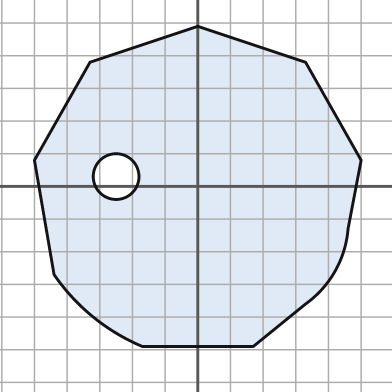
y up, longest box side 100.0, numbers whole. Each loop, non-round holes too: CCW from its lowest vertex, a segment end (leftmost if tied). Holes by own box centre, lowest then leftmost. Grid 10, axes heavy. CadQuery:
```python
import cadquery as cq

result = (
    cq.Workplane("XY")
    .moveTo(-17.0, -49.0)
    .lineTo(17.0, -49.0)
    .lineTo(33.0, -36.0)
    .threePointArc((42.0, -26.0), (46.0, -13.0))
    .lineTo(50.0, 8.0)
    .lineTo(33.0, 38.0)
    .lineTo(0.0, 49.0)
    .lineTo(-33.0, 38.0)
    .lineTo(-50.0, 8.0)
    .lineTo(-44.0, -27.0)
    .threePointArc((-32.0, -40.0), (-17.0, -49.0))
    .close()
    .moveTo(-25.0, 3.0)
    .circle(7.0)
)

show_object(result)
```